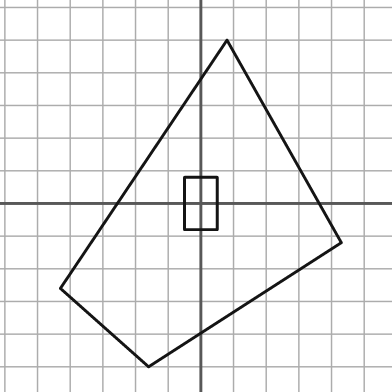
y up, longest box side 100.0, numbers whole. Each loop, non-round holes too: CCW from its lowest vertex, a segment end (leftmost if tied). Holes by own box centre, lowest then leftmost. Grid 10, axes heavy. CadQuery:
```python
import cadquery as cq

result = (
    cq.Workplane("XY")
    .moveTo(-16.0, -50.0)
    .lineTo(43.0, -12.0)
    .lineTo(8.0, 50.0)
    .lineTo(-43.0, -26.0)
    .close()
    .moveTo(-5.0, -8.0)
    .lineTo(5.0, -8.0)
    .lineTo(5.0, 8.0)
    .lineTo(-5.0, 8.0)
    .close()
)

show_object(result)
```